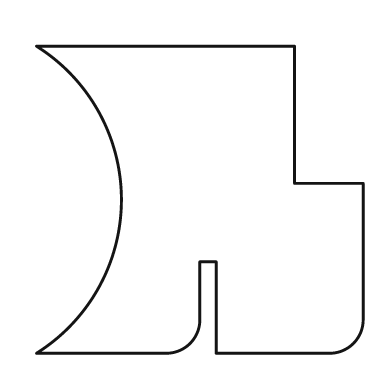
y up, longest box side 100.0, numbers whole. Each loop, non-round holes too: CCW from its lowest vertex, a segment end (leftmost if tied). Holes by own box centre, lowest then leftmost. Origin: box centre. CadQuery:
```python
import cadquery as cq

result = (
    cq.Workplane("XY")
    .moveTo(-50.0, -47.0)
    .lineTo(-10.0, -47.0)
    .threePointArc((-3.0, -44.0), (0.0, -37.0))
    .lineTo(0.0, -19.0)
    .lineTo(5.0, -19.0)
    .lineTo(5.0, -47.0)
    .lineTo(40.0, -47.0)
    .threePointArc((47.0, -44.0), (50.0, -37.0))
    .lineTo(50.0, 5.0)
    .lineTo(29.0, 5.0)
    .lineTo(29.0, 47.0)
    .lineTo(-50.0, 47.0)
    .threePointArc((-24.0, 0.0), (-50.0, -47.0))
    .close()
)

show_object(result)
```